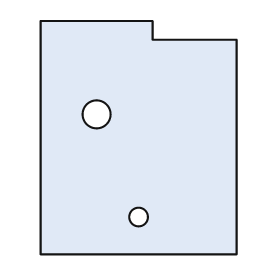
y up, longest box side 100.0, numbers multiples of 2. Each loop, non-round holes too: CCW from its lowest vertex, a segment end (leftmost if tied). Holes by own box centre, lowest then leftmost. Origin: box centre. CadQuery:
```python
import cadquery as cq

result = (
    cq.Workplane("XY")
    .moveTo(-42.0, -50.0)
    .lineTo(42.0, -50.0)
    .lineTo(42.0, 42.0)
    .lineTo(6.0, 42.0)
    .lineTo(6.0, 50.0)
    .lineTo(-42.0, 50.0)
    .close()
    .moveTo(0.0, -34.0)
    .circle(4.0)
    .moveTo(-18.0, 10.0)
    .circle(6.0)
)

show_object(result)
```